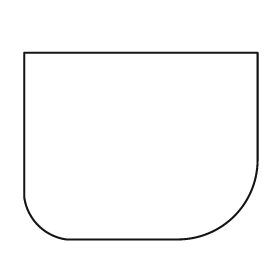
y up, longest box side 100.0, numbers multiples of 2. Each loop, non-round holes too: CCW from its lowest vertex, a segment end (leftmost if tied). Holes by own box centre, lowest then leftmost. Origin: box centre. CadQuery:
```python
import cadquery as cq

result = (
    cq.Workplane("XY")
    .moveTo(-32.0, -40.0)
    .lineTo(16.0, -40.0)
    .threePointArc((40.0, -30.0), (50.0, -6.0))
    .lineTo(50.0, 40.0)
    .lineTo(-50.0, 40.0)
    .lineTo(-50.0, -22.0)
    .threePointArc((-44.0, -34.0), (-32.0, -40.0))
    .close()
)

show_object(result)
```